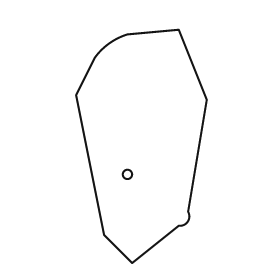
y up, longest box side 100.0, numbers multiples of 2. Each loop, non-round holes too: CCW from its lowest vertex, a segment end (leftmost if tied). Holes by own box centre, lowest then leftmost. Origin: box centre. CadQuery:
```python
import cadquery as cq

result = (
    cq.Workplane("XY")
    .moveTo(-4.0, -50.0)
    .lineTo(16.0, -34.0)
    .threePointArc((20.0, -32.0), (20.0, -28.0))
    .lineTo(28.0, 20.0)
    .lineTo(16.0, 50.0)
    .lineTo(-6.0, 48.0)
    .threePointArc((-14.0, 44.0), (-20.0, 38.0))
    .lineTo(-28.0, 22.0)
    .lineTo(-16.0, -38.0)
    .close()
    .moveTo(-6.0, -12.0)
    .circle(2.0)
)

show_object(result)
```